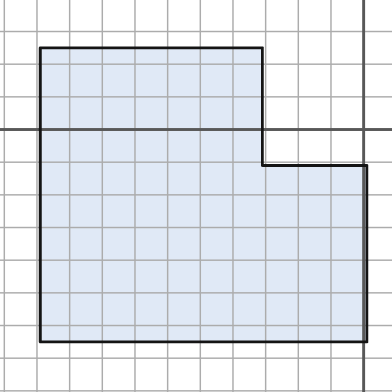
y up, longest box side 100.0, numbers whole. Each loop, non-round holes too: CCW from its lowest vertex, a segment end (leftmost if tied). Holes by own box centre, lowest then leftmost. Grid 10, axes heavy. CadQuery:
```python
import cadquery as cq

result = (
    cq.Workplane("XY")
    .moveTo(-99.0, -65.0)
    .lineTo(1.0, -65.0)
    .lineTo(1.0, -11.0)
    .lineTo(-31.0, -11.0)
    .lineTo(-31.0, 25.0)
    .lineTo(-99.0, 25.0)
    .close()
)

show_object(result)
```